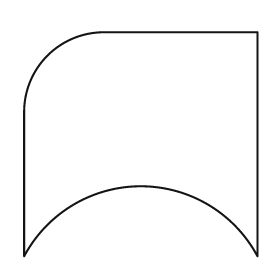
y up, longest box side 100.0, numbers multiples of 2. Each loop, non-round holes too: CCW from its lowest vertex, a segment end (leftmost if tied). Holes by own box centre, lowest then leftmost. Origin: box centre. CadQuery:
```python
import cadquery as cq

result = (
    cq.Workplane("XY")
    .moveTo(-50.0, -48.0)
    .threePointArc((0.0, -18.0), (50.0, -48.0))
    .lineTo(50.0, 48.0)
    .lineTo(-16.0, 48.0)
    .threePointArc((-40.0, 38.0), (-50.0, 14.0))
    .close()
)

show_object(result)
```